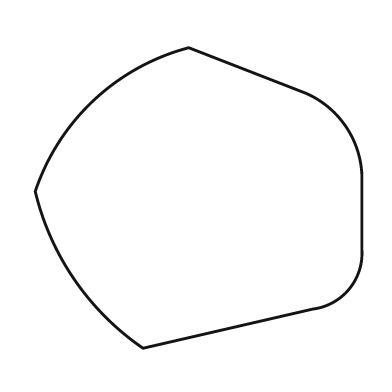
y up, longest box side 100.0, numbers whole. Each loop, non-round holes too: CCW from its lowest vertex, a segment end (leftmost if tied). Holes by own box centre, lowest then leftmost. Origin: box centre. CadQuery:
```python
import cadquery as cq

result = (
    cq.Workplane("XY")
    .moveTo(-17.0, -46.0)
    .lineTo(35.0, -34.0)
    .threePointArc((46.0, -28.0), (50.0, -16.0))
    .lineTo(50.0, 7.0)
    .threePointArc((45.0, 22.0), (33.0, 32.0))
    .lineTo(-3.0, 46.0)
    .threePointArc((-32.0, 30.0), (-50.0, 2.0))
    .threePointArc((-38.0, -25.0), (-17.0, -46.0))
    .close()
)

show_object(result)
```